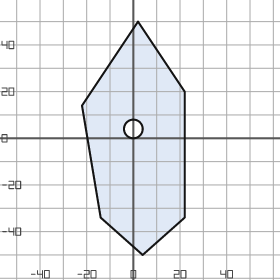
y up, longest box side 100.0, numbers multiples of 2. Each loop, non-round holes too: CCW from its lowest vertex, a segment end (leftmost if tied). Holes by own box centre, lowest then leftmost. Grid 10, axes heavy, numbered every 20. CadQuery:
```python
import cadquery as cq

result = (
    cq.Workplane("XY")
    .moveTo(4.0, -50.0)
    .lineTo(22.0, -34.0)
    .lineTo(22.0, 20.0)
    .lineTo(2.0, 50.0)
    .lineTo(-22.0, 14.0)
    .lineTo(-14.0, -34.0)
    .close()
    .moveTo(0.0, 4.0)
    .circle(4.0)
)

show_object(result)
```